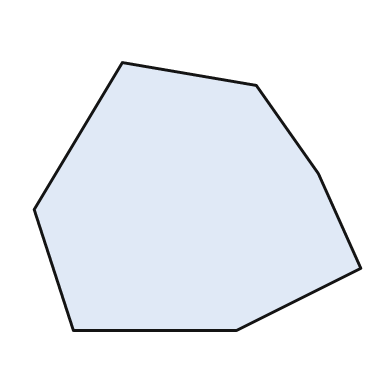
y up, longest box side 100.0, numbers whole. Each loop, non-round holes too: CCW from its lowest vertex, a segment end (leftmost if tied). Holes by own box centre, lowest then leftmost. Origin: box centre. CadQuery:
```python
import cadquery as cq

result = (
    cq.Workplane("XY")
    .moveTo(-38.0, -41.0)
    .lineTo(12.0, -41.0)
    .lineTo(50.0, -22.0)
    .lineTo(37.0, 7.0)
    .lineTo(18.0, 34.0)
    .lineTo(-23.0, 41.0)
    .lineTo(-50.0, -4.0)
    .close()
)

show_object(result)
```